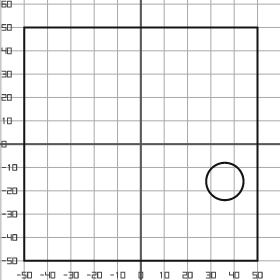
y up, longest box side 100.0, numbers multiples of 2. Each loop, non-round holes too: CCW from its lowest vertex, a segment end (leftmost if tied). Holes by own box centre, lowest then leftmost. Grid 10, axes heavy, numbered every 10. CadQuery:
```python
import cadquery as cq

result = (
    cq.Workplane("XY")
    .moveTo(-50.0, -50.0)
    .lineTo(50.0, -50.0)
    .lineTo(50.0, 50.0)
    .lineTo(-50.0, 50.0)
    .close()
    .moveTo(36.0, -16.0)
    .circle(8.0)
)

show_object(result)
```